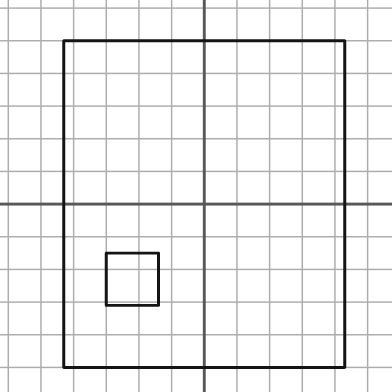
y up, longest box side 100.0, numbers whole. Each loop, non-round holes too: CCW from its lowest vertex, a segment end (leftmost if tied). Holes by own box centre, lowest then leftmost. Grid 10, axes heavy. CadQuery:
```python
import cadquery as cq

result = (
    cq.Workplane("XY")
    .moveTo(-43.0, -50.0)
    .lineTo(43.0, -50.0)
    .lineTo(43.0, 50.0)
    .lineTo(-43.0, 50.0)
    .close()
    .moveTo(-30.0, -31.0)
    .lineTo(-14.0, -31.0)
    .lineTo(-14.0, -15.0)
    .lineTo(-30.0, -15.0)
    .close()
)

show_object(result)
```